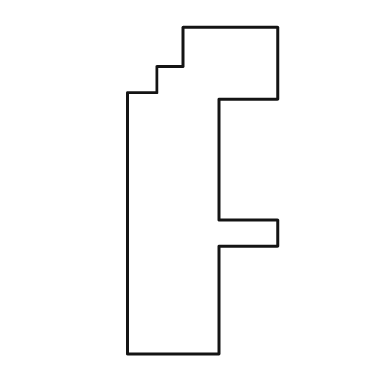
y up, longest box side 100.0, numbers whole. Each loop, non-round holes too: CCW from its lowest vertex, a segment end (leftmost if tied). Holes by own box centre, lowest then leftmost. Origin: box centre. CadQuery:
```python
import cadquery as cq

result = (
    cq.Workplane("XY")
    .moveTo(-23.0, -50.0)
    .lineTo(5.0, -50.0)
    .lineTo(5.0, -17.0)
    .lineTo(23.0, -17.0)
    .lineTo(23.0, -9.0)
    .lineTo(5.0, -9.0)
    .lineTo(5.0, 28.0)
    .lineTo(23.0, 28.0)
    .lineTo(23.0, 50.0)
    .lineTo(-6.0, 50.0)
    .lineTo(-6.0, 38.0)
    .lineTo(-14.0, 38.0)
    .lineTo(-14.0, 30.0)
    .lineTo(-23.0, 30.0)
    .close()
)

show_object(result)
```